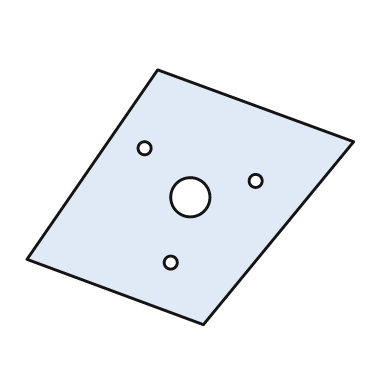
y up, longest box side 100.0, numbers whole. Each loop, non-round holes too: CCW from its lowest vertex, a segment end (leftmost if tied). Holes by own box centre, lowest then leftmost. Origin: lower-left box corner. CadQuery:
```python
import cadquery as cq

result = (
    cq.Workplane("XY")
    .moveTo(54.0, 0.0)
    .lineTo(100.0, 56.0)
    .lineTo(40.0, 78.0)
    .lineTo(0.0, 20.0)
    .close()
    .moveTo(44.0, 19.0)
    .circle(2.0)
    .moveTo(50.0, 39.0)
    .circle(6.0)
    .moveTo(70.0, 44.0)
    .circle(2.0)
    .moveTo(36.0, 54.0)
    .circle(2.0)
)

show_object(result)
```